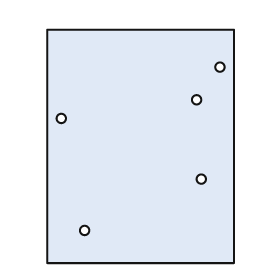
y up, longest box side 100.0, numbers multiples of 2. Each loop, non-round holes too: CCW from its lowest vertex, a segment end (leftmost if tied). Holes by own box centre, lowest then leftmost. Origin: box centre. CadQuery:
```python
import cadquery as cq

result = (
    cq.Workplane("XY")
    .moveTo(-40.0, -50.0)
    .lineTo(40.0, -50.0)
    .lineTo(40.0, 50.0)
    .lineTo(-40.0, 50.0)
    .close()
    .moveTo(-24.0, -36.0)
    .circle(2.0)
    .moveTo(26.0, -14.0)
    .circle(2.0)
    .moveTo(-34.0, 12.0)
    .circle(2.0)
    .moveTo(24.0, 20.0)
    .circle(2.0)
    .moveTo(34.0, 34.0)
    .circle(2.0)
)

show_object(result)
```